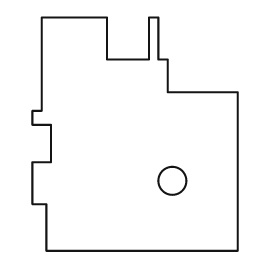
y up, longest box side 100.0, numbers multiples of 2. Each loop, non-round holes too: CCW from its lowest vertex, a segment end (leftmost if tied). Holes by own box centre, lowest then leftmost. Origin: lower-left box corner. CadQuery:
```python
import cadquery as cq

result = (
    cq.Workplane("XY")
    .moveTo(6.0, 0.0)
    .lineTo(88.0, 0.0)
    .lineTo(88.0, 68.0)
    .lineTo(58.0, 68.0)
    .lineTo(58.0, 82.0)
    .lineTo(54.0, 82.0)
    .lineTo(54.0, 100.0)
    .lineTo(50.0, 100.0)
    .lineTo(50.0, 82.0)
    .lineTo(32.0, 82.0)
    .lineTo(32.0, 100.0)
    .lineTo(4.0, 100.0)
    .lineTo(4.0, 60.0)
    .lineTo(0.0, 60.0)
    .lineTo(0.0, 54.0)
    .lineTo(8.0, 54.0)
    .lineTo(8.0, 38.0)
    .lineTo(0.0, 38.0)
    .lineTo(0.0, 20.0)
    .lineTo(6.0, 20.0)
    .close()
    .moveTo(60.0, 30.0)
    .circle(6.0)
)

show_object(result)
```